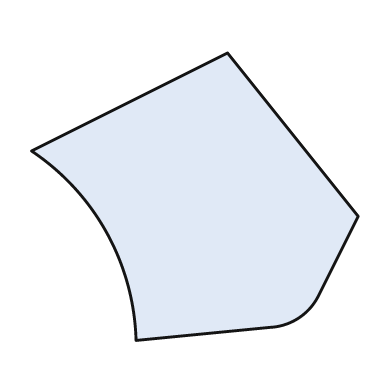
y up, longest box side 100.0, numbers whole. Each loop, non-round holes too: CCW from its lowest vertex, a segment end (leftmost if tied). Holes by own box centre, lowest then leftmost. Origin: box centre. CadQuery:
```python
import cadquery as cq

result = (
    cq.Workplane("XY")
    .moveTo(-18.0, -44.0)
    .lineTo(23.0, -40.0)
    .threePointArc((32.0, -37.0), (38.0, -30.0))
    .lineTo(50.0, -6.0)
    .lineTo(10.0, 44.0)
    .lineTo(-50.0, 14.0)
    .threePointArc((-27.0, -11.0), (-18.0, -44.0))
    .close()
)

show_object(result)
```